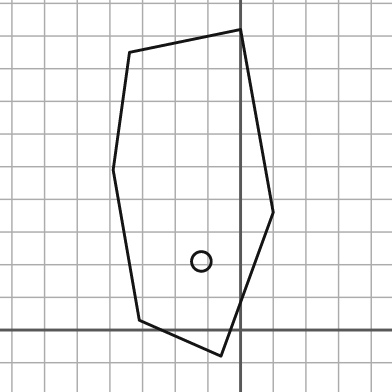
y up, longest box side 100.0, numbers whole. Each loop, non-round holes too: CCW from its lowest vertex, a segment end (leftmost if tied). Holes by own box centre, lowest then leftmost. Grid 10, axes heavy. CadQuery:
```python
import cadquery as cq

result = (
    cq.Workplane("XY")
    .moveTo(-6.0, -8.0)
    .lineTo(10.0, 36.0)
    .lineTo(0.0, 92.0)
    .lineTo(-34.0, 85.0)
    .lineTo(-39.0, 49.0)
    .lineTo(-31.0, 3.0)
    .close()
    .moveTo(-12.0, 21.0)
    .circle(3.0)
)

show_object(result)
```